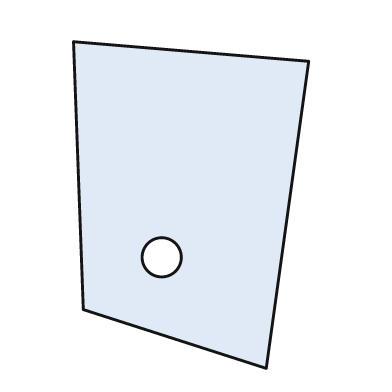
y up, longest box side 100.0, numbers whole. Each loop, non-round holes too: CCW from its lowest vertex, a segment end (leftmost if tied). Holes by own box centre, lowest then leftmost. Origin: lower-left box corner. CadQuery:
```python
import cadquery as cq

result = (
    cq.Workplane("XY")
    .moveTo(59.0, 0.0)
    .lineTo(72.0, 94.0)
    .lineTo(0.0, 100.0)
    .lineTo(3.0, 18.0)
    .close()
    .moveTo(27.0, 34.0)
    .circle(6.0)
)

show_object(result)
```